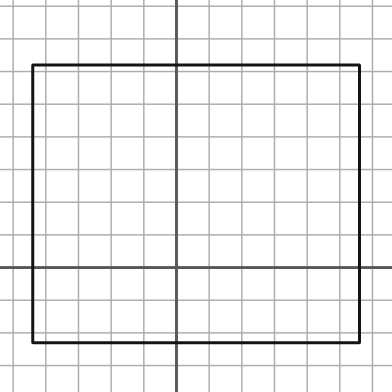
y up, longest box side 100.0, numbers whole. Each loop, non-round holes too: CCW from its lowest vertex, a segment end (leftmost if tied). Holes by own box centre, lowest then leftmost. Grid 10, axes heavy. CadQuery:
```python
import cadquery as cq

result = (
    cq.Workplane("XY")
    .moveTo(-44.0, -23.0)
    .lineTo(56.0, -23.0)
    .lineTo(56.0, 62.0)
    .lineTo(-44.0, 62.0)
    .close()
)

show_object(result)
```